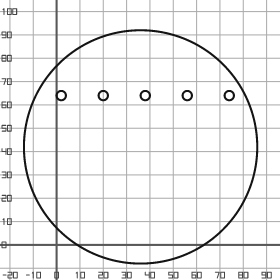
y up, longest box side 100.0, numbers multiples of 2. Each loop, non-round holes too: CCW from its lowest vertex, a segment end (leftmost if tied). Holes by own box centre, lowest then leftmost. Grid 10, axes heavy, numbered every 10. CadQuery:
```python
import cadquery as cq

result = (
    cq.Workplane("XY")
    .moveTo(36.0, 42.0)
    .circle(50.0)
    .moveTo(2.0, 64.0)
    .circle(2.0)
    .moveTo(20.0, 64.0)
    .circle(2.0)
    .moveTo(38.0, 64.0)
    .circle(2.0)
    .moveTo(56.0, 64.0)
    .circle(2.0)
    .moveTo(74.0, 64.0)
    .circle(2.0)
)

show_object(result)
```